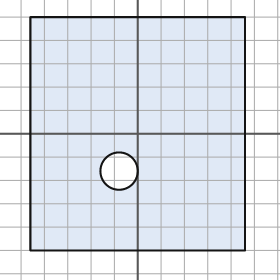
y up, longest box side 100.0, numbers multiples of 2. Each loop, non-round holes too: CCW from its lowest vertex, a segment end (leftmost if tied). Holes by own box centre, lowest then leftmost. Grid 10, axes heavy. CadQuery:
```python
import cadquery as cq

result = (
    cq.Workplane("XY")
    .moveTo(-46.0, -50.0)
    .lineTo(46.0, -50.0)
    .lineTo(46.0, 50.0)
    .lineTo(-46.0, 50.0)
    .close()
    .moveTo(-8.0, -16.0)
    .circle(8.0)
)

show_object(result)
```